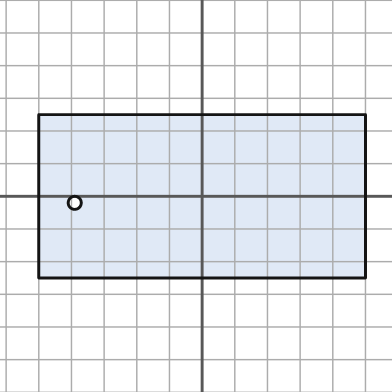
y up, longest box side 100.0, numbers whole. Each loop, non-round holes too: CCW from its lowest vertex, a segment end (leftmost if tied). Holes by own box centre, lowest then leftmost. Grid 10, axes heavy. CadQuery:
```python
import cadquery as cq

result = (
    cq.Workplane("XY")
    .moveTo(-50.0, -25.0)
    .lineTo(50.0, -25.0)
    .lineTo(50.0, 25.0)
    .lineTo(-50.0, 25.0)
    .close()
    .moveTo(-39.0, -2.0)
    .circle(2.0)
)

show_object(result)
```